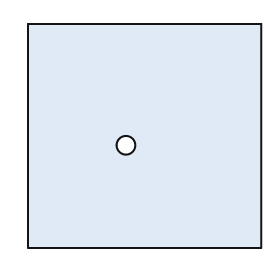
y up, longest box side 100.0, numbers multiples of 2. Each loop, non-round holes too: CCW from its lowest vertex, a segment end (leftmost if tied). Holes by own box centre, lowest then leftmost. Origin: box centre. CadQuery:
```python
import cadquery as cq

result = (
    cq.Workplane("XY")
    .moveTo(-50.0, -48.0)
    .lineTo(50.0, -48.0)
    .lineTo(50.0, 48.0)
    .lineTo(-50.0, 48.0)
    .close()
    .moveTo(-8.0, -4.0)
    .circle(4.0)
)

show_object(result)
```